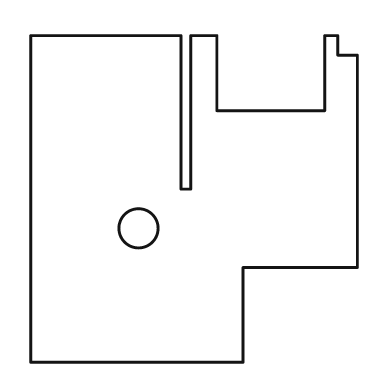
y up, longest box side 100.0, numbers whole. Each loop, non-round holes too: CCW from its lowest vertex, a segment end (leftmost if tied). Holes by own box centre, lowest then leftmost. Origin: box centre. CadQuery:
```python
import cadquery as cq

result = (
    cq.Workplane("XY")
    .moveTo(-50.0, -50.0)
    .lineTo(15.0, -50.0)
    .lineTo(15.0, -21.0)
    .lineTo(50.0, -21.0)
    .lineTo(50.0, 44.0)
    .lineTo(44.0, 44.0)
    .lineTo(44.0, 50.0)
    .lineTo(40.0, 50.0)
    .lineTo(40.0, 27.0)
    .lineTo(7.0, 27.0)
    .lineTo(7.0, 50.0)
    .lineTo(-1.0, 50.0)
    .lineTo(-1.0, 3.0)
    .lineTo(-4.0, 3.0)
    .lineTo(-4.0, 50.0)
    .lineTo(-50.0, 50.0)
    .close()
    .moveTo(-17.0, -9.0)
    .circle(6.0)
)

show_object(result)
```